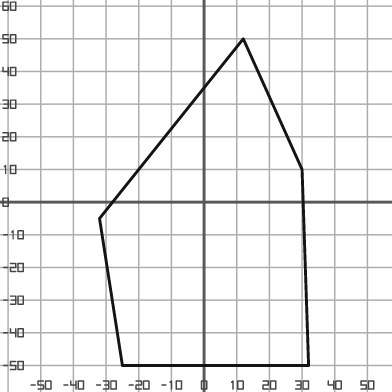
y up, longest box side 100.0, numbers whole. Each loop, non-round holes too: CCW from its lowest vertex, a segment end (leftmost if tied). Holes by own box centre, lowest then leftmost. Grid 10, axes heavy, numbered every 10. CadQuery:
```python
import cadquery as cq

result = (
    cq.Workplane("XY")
    .moveTo(-25.0, -50.0)
    .lineTo(32.0, -50.0)
    .lineTo(30.0, 10.0)
    .lineTo(12.0, 50.0)
    .lineTo(-32.0, -5.0)
    .close()
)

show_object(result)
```